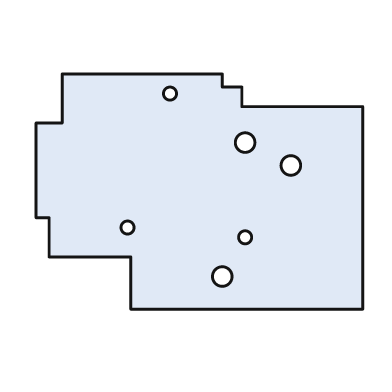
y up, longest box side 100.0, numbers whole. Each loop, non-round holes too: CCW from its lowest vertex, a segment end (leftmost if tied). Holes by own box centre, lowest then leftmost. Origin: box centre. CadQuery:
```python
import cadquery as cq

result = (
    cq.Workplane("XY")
    .moveTo(-21.0, -36.0)
    .lineTo(50.0, -36.0)
    .lineTo(50.0, 26.0)
    .lineTo(13.0, 26.0)
    .lineTo(13.0, 32.0)
    .lineTo(7.0, 32.0)
    .lineTo(7.0, 36.0)
    .lineTo(-42.0, 36.0)
    .lineTo(-42.0, 21.0)
    .lineTo(-50.0, 21.0)
    .lineTo(-50.0, -8.0)
    .lineTo(-46.0, -8.0)
    .lineTo(-46.0, -20.0)
    .lineTo(-21.0, -20.0)
    .close()
    .moveTo(7.0, -26.0)
    .circle(3.0)
    .moveTo(14.0, -14.0)
    .circle(2.0)
    .moveTo(-22.0, -11.0)
    .circle(2.0)
    .moveTo(28.0, 8.0)
    .circle(3.0)
    .moveTo(14.0, 15.0)
    .circle(3.0)
    .moveTo(-9.0, 30.0)
    .circle(2.0)
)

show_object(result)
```